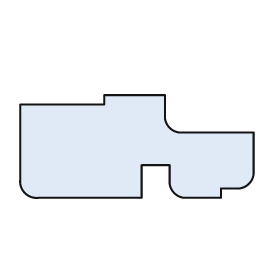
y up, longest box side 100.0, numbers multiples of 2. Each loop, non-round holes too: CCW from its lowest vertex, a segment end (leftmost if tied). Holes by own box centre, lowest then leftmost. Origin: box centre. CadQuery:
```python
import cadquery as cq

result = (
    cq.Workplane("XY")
    .moveTo(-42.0, -22.0)
    .lineTo(2.0, -22.0)
    .lineTo(2.0, -8.0)
    .lineTo(14.0, -8.0)
    .lineTo(14.0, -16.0)
    .threePointArc((16.0, -20.0), (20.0, -22.0))
    .lineTo(36.0, -22.0)
    .lineTo(36.0, -18.0)
    .lineTo(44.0, -18.0)
    .threePointArc((48.0, -16.0), (50.0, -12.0))
    .lineTo(50.0, 6.0)
    .lineTo(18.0, 6.0)
    .threePointArc((14.0, 8.0), (12.0, 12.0))
    .lineTo(12.0, 22.0)
    .lineTo(-14.0, 22.0)
    .lineTo(-14.0, 18.0)
    .lineTo(-50.0, 18.0)
    .lineTo(-50.0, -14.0)
    .threePointArc((-48.0, -20.0), (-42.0, -22.0))
    .close()
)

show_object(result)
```